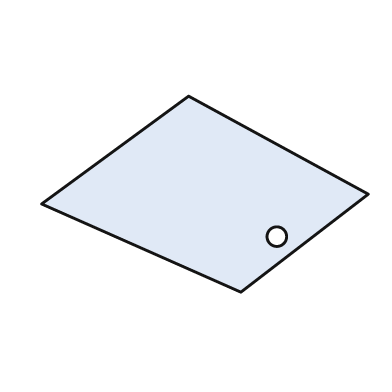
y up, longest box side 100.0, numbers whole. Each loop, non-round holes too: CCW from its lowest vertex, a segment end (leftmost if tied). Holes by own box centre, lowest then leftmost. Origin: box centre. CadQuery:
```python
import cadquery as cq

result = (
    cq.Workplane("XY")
    .moveTo(11.0, -30.0)
    .lineTo(50.0, 0.0)
    .lineTo(-5.0, 30.0)
    .lineTo(-50.0, -3.0)
    .close()
    .moveTo(22.0, -13.0)
    .circle(3.0)
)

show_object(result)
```